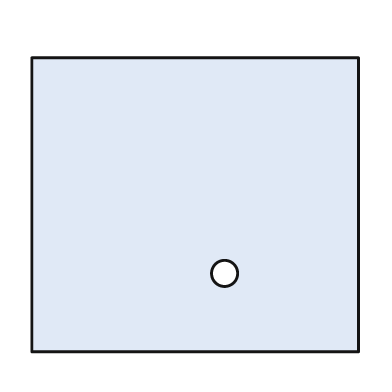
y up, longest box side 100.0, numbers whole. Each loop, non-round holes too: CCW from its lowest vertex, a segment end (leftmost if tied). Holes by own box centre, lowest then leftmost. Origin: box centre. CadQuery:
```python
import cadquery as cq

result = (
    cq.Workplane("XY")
    .moveTo(-50.0, -45.0)
    .lineTo(50.0, -45.0)
    .lineTo(50.0, 45.0)
    .lineTo(-50.0, 45.0)
    .close()
    .moveTo(9.0, -21.0)
    .circle(4.0)
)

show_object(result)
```